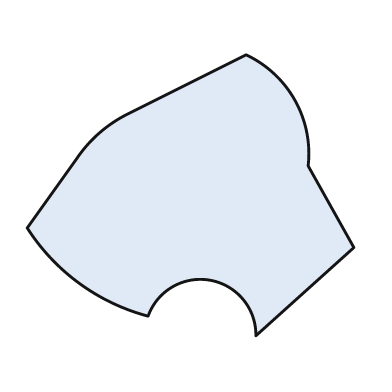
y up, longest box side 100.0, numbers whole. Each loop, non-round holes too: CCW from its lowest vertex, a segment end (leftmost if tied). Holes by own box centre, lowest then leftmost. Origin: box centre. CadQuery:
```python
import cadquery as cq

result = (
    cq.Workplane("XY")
    .moveTo(20.0, -43.0)
    .lineTo(50.0, -16.0)
    .lineTo(36.0, 9.0)
    .threePointArc((32.0, 29.0), (17.0, 43.0))
    .lineTo(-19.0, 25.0)
    .threePointArc((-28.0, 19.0), (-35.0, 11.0))
    .lineTo(-50.0, -10.0)
    .threePointArc((-34.0, -27.0), (-13.0, -37.0))
    .threePointArc((6.0, -26.0), (20.0, -43.0))
    .close()
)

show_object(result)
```